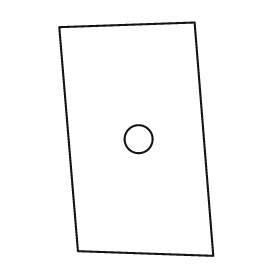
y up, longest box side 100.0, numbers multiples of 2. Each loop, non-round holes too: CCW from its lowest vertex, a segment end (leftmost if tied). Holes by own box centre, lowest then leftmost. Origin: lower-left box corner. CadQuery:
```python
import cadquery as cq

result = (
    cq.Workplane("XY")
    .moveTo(66.0, 0.0)
    .lineTo(58.0, 100.0)
    .lineTo(0.0, 98.0)
    .lineTo(8.0, 2.0)
    .close()
    .moveTo(34.0, 50.0)
    .circle(6.0)
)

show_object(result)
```